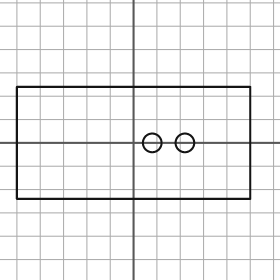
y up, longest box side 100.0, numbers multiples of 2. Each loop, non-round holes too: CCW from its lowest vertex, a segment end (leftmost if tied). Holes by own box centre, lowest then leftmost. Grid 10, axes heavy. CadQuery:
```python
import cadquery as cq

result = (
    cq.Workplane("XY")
    .moveTo(-50.0, -24.0)
    .lineTo(50.0, -24.0)
    .lineTo(50.0, 24.0)
    .lineTo(-50.0, 24.0)
    .close()
    .moveTo(8.0, 0.0)
    .circle(4.0)
    .moveTo(22.0, 0.0)
    .circle(4.0)
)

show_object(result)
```